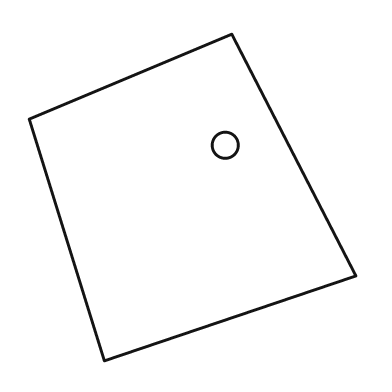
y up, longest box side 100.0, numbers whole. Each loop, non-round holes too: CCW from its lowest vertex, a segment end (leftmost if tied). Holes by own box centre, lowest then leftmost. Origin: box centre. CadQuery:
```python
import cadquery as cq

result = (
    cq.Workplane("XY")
    .moveTo(-27.0, -50.0)
    .lineTo(50.0, -24.0)
    .lineTo(12.0, 50.0)
    .lineTo(-50.0, 24.0)
    .close()
    .moveTo(10.0, 16.0)
    .circle(4.0)
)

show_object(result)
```